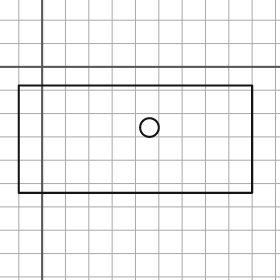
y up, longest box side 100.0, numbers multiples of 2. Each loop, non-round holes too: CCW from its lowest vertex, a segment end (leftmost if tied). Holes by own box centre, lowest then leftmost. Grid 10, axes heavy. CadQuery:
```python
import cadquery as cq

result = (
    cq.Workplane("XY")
    .moveTo(-10.0, -54.0)
    .lineTo(90.0, -54.0)
    .lineTo(90.0, -8.0)
    .lineTo(-10.0, -8.0)
    .close()
    .moveTo(46.0, -26.0)
    .circle(4.0)
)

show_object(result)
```